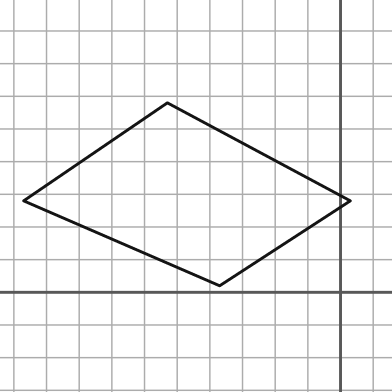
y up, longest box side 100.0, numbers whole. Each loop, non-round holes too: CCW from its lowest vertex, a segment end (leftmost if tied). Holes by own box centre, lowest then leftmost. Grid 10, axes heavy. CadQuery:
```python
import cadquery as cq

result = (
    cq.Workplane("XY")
    .moveTo(-37.0, 2.0)
    .lineTo(3.0, 28.0)
    .lineTo(-53.0, 58.0)
    .lineTo(-97.0, 28.0)
    .close()
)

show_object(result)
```